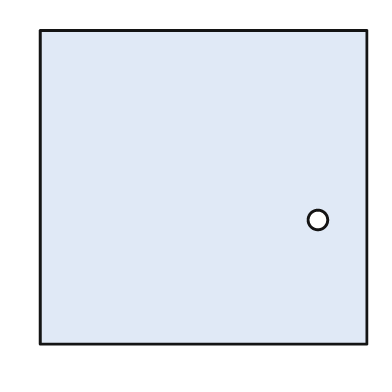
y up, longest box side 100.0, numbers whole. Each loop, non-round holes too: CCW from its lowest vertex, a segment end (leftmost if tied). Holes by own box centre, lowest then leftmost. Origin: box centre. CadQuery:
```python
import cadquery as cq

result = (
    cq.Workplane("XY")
    .moveTo(-50.0, -48.0)
    .lineTo(50.0, -48.0)
    .lineTo(50.0, 48.0)
    .lineTo(-50.0, 48.0)
    .close()
    .moveTo(35.0, -10.0)
    .circle(3.0)
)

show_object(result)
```